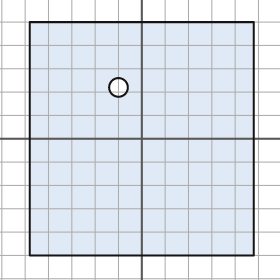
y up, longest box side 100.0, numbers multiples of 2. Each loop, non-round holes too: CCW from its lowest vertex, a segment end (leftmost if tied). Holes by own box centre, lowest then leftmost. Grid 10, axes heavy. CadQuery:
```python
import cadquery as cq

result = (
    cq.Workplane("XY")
    .moveTo(-48.0, -50.0)
    .lineTo(48.0, -50.0)
    .lineTo(48.0, 50.0)
    .lineTo(-48.0, 50.0)
    .close()
    .moveTo(-10.0, 22.0)
    .circle(4.0)
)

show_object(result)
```